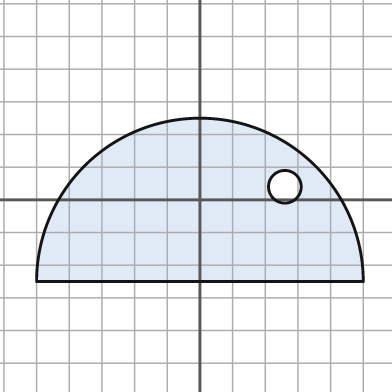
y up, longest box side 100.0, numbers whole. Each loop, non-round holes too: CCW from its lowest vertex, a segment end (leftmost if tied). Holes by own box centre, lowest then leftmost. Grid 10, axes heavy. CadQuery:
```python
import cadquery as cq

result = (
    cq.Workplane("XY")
    .moveTo(-50.0, -25.0)
    .lineTo(50.0, -25.0)
    .threePointArc((0.0, 25.0), (-50.0, -25.0))
    .close()
    .moveTo(26.0, 4.0)
    .circle(5.0)
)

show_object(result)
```